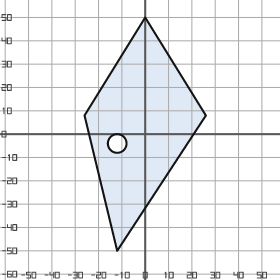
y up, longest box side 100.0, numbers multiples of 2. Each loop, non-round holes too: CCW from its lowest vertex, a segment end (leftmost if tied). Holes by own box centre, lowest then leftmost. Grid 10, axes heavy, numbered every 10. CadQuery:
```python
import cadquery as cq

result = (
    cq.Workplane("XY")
    .moveTo(-12.0, -50.0)
    .lineTo(26.0, 8.0)
    .lineTo(0.0, 50.0)
    .lineTo(-26.0, 8.0)
    .close()
    .moveTo(-12.0, -4.0)
    .circle(4.0)
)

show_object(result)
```